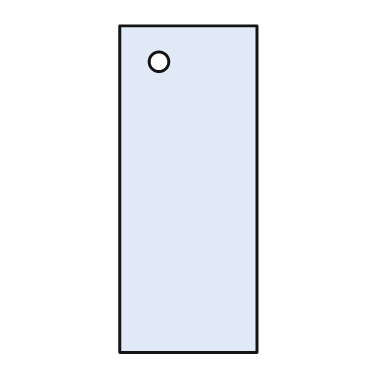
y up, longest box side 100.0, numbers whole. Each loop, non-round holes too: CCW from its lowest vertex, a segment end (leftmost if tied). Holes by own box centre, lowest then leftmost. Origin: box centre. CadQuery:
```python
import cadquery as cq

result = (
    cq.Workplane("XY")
    .moveTo(-21.0, -50.0)
    .lineTo(21.0, -50.0)
    .lineTo(21.0, 50.0)
    .lineTo(-21.0, 50.0)
    .close()
    .moveTo(-9.0, 39.0)
    .circle(3.0)
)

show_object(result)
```